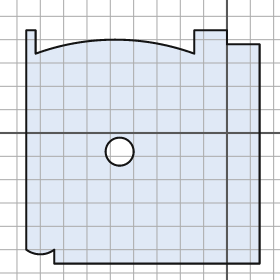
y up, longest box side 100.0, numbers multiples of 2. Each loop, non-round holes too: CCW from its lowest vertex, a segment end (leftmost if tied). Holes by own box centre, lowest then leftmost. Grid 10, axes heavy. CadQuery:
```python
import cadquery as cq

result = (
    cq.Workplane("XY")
    .moveTo(-74.0, -56.0)
    .lineTo(14.0, -56.0)
    .lineTo(14.0, 38.0)
    .lineTo(0.0, 38.0)
    .lineTo(0.0, 44.0)
    .lineTo(-14.0, 44.0)
    .lineTo(-14.0, 34.0)
    .threePointArc((-48.0, 40.0), (-82.0, 34.0))
    .lineTo(-82.0, 44.0)
    .lineTo(-86.0, 44.0)
    .lineTo(-86.0, -50.0)
    .threePointArc((-80.0, -52.0), (-74.0, -50.0))
    .close()
    .moveTo(-46.0, -8.0)
    .circle(6.0)
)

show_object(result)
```